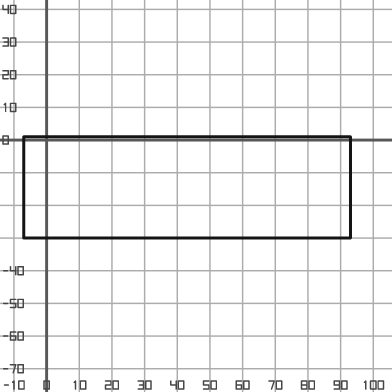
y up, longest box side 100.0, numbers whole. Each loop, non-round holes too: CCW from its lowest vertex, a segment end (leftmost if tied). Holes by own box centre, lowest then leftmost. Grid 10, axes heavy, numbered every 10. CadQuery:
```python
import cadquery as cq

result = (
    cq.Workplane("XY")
    .moveTo(-7.0, -30.0)
    .lineTo(93.0, -30.0)
    .lineTo(93.0, 1.0)
    .lineTo(-7.0, 1.0)
    .close()
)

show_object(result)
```